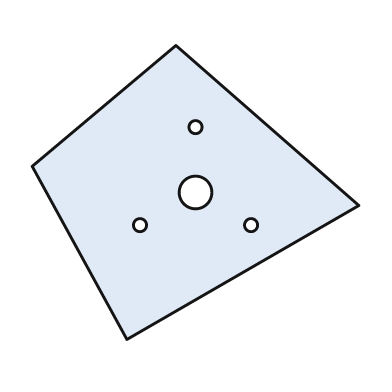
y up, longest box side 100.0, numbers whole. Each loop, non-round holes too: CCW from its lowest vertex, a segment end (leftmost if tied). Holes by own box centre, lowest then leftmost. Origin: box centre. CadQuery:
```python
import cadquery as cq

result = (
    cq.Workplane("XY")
    .moveTo(-21.0, -45.0)
    .lineTo(50.0, -4.0)
    .lineTo(-6.0, 45.0)
    .lineTo(-50.0, 8.0)
    .close()
    .moveTo(-17.0, -10.0)
    .circle(2.0)
    .moveTo(17.0, -10.0)
    .circle(2.0)
    .moveTo(0.0, 0.0)
    .circle(5.0)
    .moveTo(0.0, 20.0)
    .circle(2.0)
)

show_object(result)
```